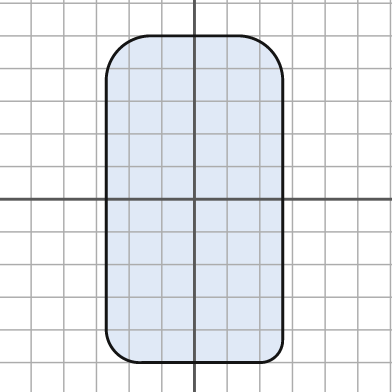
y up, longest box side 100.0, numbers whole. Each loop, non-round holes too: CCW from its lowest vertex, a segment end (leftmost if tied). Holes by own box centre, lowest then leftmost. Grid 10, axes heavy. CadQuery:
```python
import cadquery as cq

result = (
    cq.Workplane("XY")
    .moveTo(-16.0, -50.0)
    .lineTo(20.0, -50.0)
    .threePointArc((25.0, -48.0), (27.0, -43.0))
    .lineTo(27.0, 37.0)
    .threePointArc((23.0, 46.0), (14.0, 50.0))
    .lineTo(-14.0, 50.0)
    .threePointArc((-23.0, 46.0), (-27.0, 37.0))
    .lineTo(-27.0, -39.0)
    .threePointArc((-24.0, -47.0), (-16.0, -50.0))
    .close()
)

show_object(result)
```